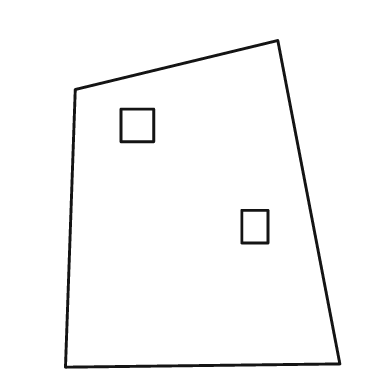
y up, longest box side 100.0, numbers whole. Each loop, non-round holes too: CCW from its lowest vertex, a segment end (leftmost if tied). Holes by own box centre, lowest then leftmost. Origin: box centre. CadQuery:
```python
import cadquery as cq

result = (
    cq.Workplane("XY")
    .moveTo(-42.0, -50.0)
    .lineTo(42.0, -49.0)
    .lineTo(23.0, 50.0)
    .lineTo(-39.0, 35.0)
    .close()
    .moveTo(12.0, -12.0)
    .lineTo(20.0, -12.0)
    .lineTo(20.0, -2.0)
    .lineTo(12.0, -2.0)
    .close()
    .moveTo(-25.0, 19.0)
    .lineTo(-15.0, 19.0)
    .lineTo(-15.0, 29.0)
    .lineTo(-25.0, 29.0)
    .close()
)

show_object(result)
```